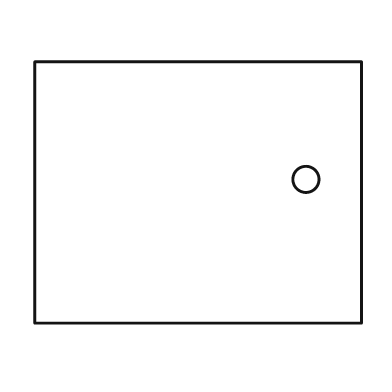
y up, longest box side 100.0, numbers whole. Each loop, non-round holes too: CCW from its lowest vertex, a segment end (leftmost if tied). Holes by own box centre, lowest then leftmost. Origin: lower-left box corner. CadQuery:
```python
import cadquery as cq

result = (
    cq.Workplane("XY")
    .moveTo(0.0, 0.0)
    .lineTo(100.0, 0.0)
    .lineTo(100.0, 80.0)
    .lineTo(0.0, 80.0)
    .close()
    .moveTo(83.0, 44.0)
    .circle(4.0)
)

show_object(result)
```